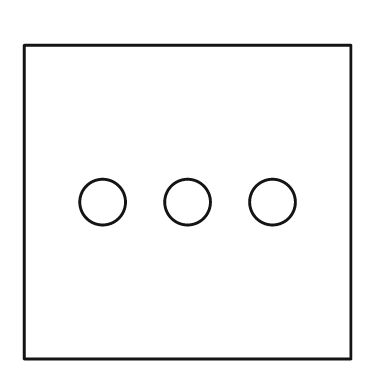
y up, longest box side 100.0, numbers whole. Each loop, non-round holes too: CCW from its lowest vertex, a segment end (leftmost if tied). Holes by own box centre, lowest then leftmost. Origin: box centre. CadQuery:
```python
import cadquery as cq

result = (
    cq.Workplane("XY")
    .moveTo(-50.0, -48.0)
    .lineTo(50.0, -48.0)
    .lineTo(50.0, 48.0)
    .lineTo(-50.0, 48.0)
    .close()
    .moveTo(-26.0, 0.0)
    .circle(7.0)
    .moveTo(0.0, 0.0)
    .circle(7.0)
    .moveTo(26.0, 0.0)
    .circle(7.0)
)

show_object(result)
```